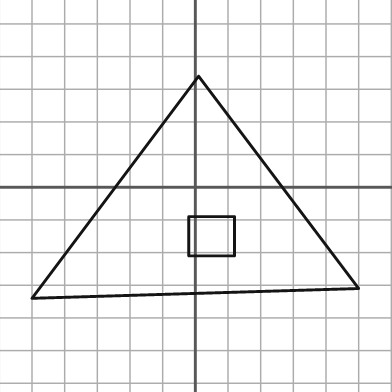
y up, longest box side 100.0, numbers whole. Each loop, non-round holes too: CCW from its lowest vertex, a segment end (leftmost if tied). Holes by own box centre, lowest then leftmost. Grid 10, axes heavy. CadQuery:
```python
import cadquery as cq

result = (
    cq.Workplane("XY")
    .moveTo(-50.0, -34.0)
    .lineTo(50.0, -31.0)
    .lineTo(1.0, 34.0)
    .close()
    .moveTo(-2.0, -21.0)
    .lineTo(12.0, -21.0)
    .lineTo(12.0, -9.0)
    .lineTo(-2.0, -9.0)
    .close()
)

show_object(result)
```